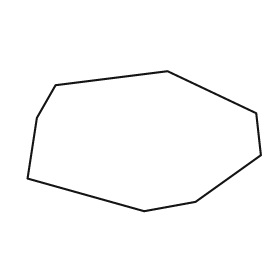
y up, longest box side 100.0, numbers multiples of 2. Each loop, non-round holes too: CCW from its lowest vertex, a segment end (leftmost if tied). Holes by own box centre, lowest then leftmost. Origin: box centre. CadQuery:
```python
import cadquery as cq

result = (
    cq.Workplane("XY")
    .moveTo(0.0, -30.0)
    .lineTo(22.0, -26.0)
    .lineTo(50.0, -6.0)
    .lineTo(48.0, 12.0)
    .lineTo(10.0, 30.0)
    .lineTo(-38.0, 24.0)
    .lineTo(-46.0, 10.0)
    .lineTo(-50.0, -16.0)
    .close()
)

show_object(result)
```